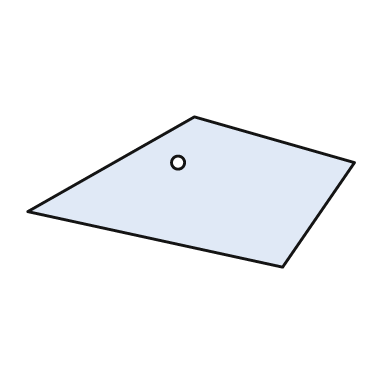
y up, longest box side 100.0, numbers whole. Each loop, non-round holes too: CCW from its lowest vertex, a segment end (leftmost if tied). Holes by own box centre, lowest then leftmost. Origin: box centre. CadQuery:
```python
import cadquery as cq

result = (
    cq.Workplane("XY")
    .moveTo(28.0, -23.0)
    .lineTo(50.0, 9.0)
    .lineTo(1.0, 23.0)
    .lineTo(-50.0, -6.0)
    .close()
    .moveTo(-4.0, 9.0)
    .circle(2.0)
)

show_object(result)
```